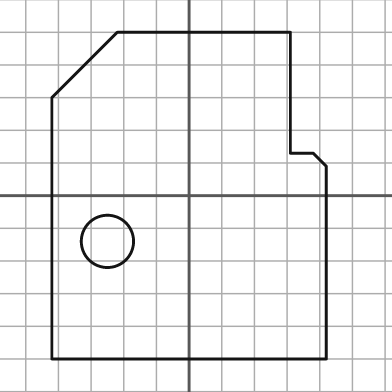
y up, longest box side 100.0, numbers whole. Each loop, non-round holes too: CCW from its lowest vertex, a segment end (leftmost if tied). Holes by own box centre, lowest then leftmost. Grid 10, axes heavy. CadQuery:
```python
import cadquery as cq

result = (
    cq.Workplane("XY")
    .moveTo(-42.0, -50.0)
    .lineTo(42.0, -50.0)
    .lineTo(42.0, 9.0)
    .lineTo(38.0, 13.0)
    .lineTo(31.0, 13.0)
    .lineTo(31.0, 50.0)
    .lineTo(-22.0, 50.0)
    .lineTo(-42.0, 30.0)
    .close()
    .moveTo(-25.0, -14.0)
    .circle(8.0)
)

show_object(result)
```